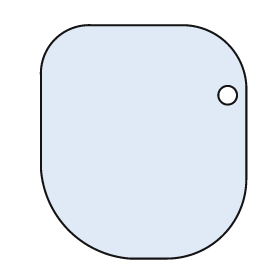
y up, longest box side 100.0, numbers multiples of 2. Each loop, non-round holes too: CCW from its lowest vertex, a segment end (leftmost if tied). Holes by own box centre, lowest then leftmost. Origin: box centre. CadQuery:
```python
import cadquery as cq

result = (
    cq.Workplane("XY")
    .moveTo(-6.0, -50.0)
    .lineTo(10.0, -50.0)
    .threePointArc((34.0, -40.0), (44.0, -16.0))
    .lineTo(44.0, 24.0)
    .threePointArc((36.0, 42.0), (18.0, 50.0))
    .lineTo(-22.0, 50.0)
    .threePointArc((-38.0, 44.0), (-44.0, 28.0))
    .lineTo(-44.0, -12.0)
    .threePointArc((-32.0, -38.0), (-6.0, -50.0))
    .close()
    .moveTo(36.0, 20.0)
    .circle(4.0)
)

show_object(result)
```